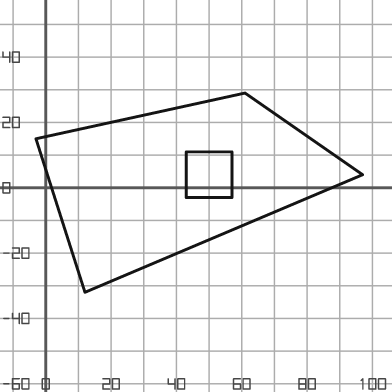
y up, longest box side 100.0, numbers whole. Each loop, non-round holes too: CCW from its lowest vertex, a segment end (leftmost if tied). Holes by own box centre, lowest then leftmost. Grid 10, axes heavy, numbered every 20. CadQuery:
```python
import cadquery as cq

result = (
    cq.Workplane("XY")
    .moveTo(12.0, -32.0)
    .lineTo(97.0, 4.0)
    .lineTo(61.0, 29.0)
    .lineTo(-3.0, 15.0)
    .close()
    .moveTo(43.0, -3.0)
    .lineTo(57.0, -3.0)
    .lineTo(57.0, 11.0)
    .lineTo(43.0, 11.0)
    .close()
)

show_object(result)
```